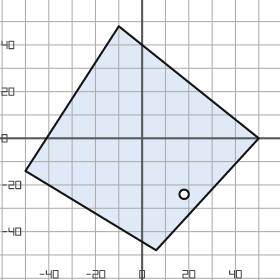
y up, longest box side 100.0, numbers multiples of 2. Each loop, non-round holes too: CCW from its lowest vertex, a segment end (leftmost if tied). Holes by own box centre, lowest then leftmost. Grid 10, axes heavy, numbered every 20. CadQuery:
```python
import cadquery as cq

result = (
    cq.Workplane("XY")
    .moveTo(6.0, -48.0)
    .lineTo(50.0, 0.0)
    .lineTo(-10.0, 48.0)
    .lineTo(-50.0, -14.0)
    .close()
    .moveTo(18.0, -24.0)
    .circle(2.0)
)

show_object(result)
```